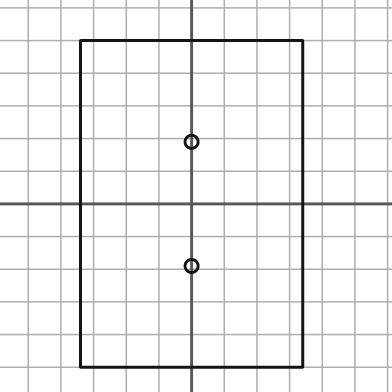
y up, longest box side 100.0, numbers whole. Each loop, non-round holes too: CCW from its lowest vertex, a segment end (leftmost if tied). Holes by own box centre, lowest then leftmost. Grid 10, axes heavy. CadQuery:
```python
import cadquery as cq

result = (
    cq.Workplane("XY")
    .moveTo(-34.0, -50.0)
    .lineTo(34.0, -50.0)
    .lineTo(34.0, 50.0)
    .lineTo(-34.0, 50.0)
    .close()
    .moveTo(0.0, -19.0)
    .circle(2.0)
    .moveTo(0.0, 19.0)
    .circle(2.0)
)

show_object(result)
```